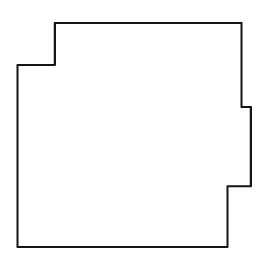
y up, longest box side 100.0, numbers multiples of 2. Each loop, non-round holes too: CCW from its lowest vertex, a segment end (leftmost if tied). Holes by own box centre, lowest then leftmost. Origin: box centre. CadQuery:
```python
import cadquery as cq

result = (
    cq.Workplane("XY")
    .moveTo(-50.0, -48.0)
    .lineTo(40.0, -48.0)
    .lineTo(40.0, -22.0)
    .lineTo(50.0, -22.0)
    .lineTo(50.0, 12.0)
    .lineTo(46.0, 12.0)
    .lineTo(46.0, 48.0)
    .lineTo(-34.0, 48.0)
    .lineTo(-34.0, 30.0)
    .lineTo(-50.0, 30.0)
    .close()
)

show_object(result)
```